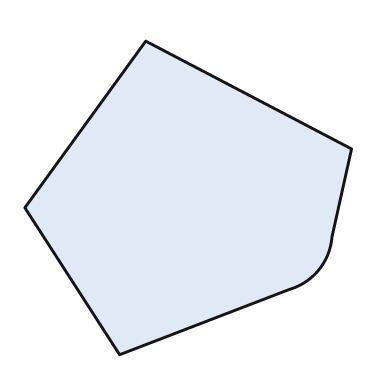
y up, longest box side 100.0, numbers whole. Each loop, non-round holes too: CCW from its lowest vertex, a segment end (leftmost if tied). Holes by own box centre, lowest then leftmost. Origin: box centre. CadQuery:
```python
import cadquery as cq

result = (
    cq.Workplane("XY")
    .moveTo(-21.0, -48.0)
    .lineTo(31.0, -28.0)
    .threePointArc((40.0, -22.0), (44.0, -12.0))
    .lineTo(50.0, 15.0)
    .lineTo(-13.0, 48.0)
    .lineTo(-50.0, -3.0)
    .close()
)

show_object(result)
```